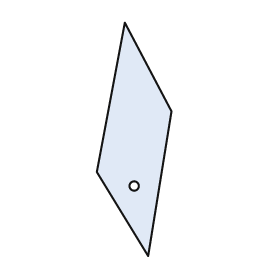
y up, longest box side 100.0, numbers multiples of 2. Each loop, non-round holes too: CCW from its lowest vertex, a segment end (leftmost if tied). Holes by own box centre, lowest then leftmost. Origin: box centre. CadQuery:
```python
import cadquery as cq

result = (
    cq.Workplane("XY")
    .moveTo(6.0, -50.0)
    .lineTo(16.0, 12.0)
    .lineTo(-4.0, 50.0)
    .lineTo(-16.0, -14.0)
    .close()
    .moveTo(0.0, -20.0)
    .circle(2.0)
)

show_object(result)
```